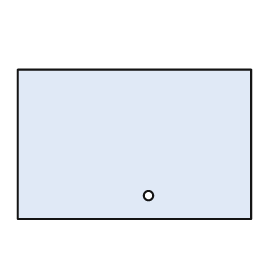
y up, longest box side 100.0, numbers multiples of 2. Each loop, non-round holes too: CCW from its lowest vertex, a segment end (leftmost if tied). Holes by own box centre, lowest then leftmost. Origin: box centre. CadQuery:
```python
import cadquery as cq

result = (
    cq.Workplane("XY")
    .moveTo(-50.0, -32.0)
    .lineTo(50.0, -32.0)
    .lineTo(50.0, 32.0)
    .lineTo(-50.0, 32.0)
    .close()
    .moveTo(6.0, -22.0)
    .circle(2.0)
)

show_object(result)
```